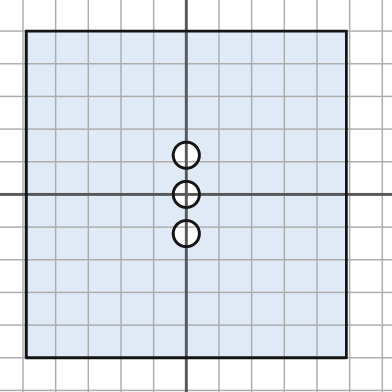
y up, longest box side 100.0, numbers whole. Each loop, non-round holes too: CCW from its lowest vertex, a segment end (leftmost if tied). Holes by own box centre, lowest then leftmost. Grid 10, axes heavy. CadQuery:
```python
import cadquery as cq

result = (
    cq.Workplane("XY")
    .moveTo(-49.0, -50.0)
    .lineTo(49.0, -50.0)
    .lineTo(49.0, 50.0)
    .lineTo(-49.0, 50.0)
    .close()
    .moveTo(0.0, -12.0)
    .circle(4.0)
    .moveTo(0.0, 0.0)
    .circle(4.0)
    .moveTo(0.0, 12.0)
    .circle(4.0)
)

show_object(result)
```